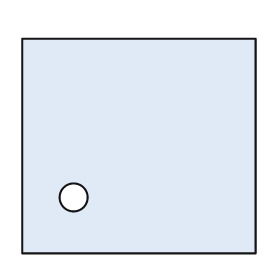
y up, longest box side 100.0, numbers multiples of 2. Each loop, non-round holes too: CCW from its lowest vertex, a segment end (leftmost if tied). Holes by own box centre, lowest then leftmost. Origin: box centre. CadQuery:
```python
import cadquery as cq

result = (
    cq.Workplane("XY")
    .moveTo(-50.0, -46.0)
    .lineTo(50.0, -46.0)
    .lineTo(50.0, 46.0)
    .lineTo(-50.0, 46.0)
    .close()
    .moveTo(-28.0, -22.0)
    .circle(6.0)
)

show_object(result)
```